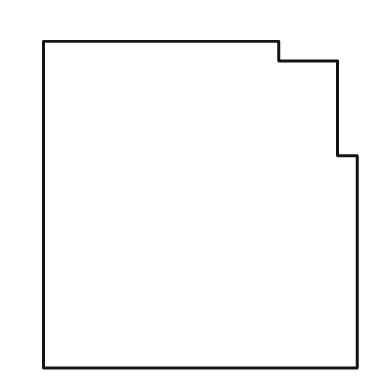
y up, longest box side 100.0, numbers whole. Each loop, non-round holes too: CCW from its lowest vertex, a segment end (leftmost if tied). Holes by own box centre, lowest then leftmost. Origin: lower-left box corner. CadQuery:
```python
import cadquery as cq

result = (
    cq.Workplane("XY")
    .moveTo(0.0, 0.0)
    .lineTo(96.0, 0.0)
    .lineTo(96.0, 65.0)
    .lineTo(90.0, 65.0)
    .lineTo(90.0, 94.0)
    .lineTo(72.0, 94.0)
    .lineTo(72.0, 100.0)
    .lineTo(0.0, 100.0)
    .close()
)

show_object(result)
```